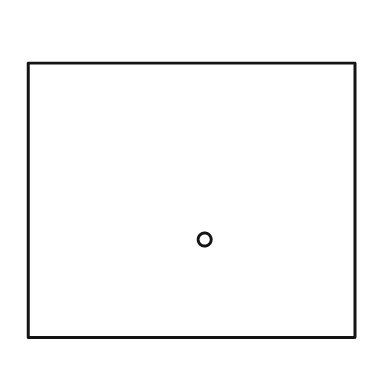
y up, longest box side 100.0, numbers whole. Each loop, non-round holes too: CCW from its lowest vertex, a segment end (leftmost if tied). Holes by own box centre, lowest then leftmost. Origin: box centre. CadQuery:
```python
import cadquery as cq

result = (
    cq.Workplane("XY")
    .moveTo(-50.0, -42.0)
    .lineTo(50.0, -42.0)
    .lineTo(50.0, 42.0)
    .lineTo(-50.0, 42.0)
    .close()
    .moveTo(4.0, -12.0)
    .circle(2.0)
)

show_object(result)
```